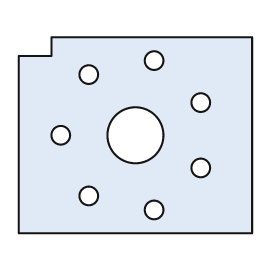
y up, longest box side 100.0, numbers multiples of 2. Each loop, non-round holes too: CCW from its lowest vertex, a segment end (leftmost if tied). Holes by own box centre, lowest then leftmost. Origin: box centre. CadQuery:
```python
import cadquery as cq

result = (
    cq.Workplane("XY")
    .moveTo(-50.0, -42.0)
    .lineTo(50.0, -42.0)
    .lineTo(50.0, 42.0)
    .lineTo(-36.0, 42.0)
    .lineTo(-36.0, 34.0)
    .lineTo(-50.0, 34.0)
    .close()
    .moveTo(8.0, -32.0)
    .circle(4.0)
    .moveTo(-20.0, -26.0)
    .circle(4.0)
    .moveTo(28.0, -14.0)
    .circle(4.0)
    .moveTo(-32.0, 0.0)
    .circle(4.0)
    .moveTo(0.0, 0.0)
    .circle(12.0)
    .moveTo(28.0, 14.0)
    .circle(4.0)
    .moveTo(-20.0, 26.0)
    .circle(4.0)
    .moveTo(8.0, 32.0)
    .circle(4.0)
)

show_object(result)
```